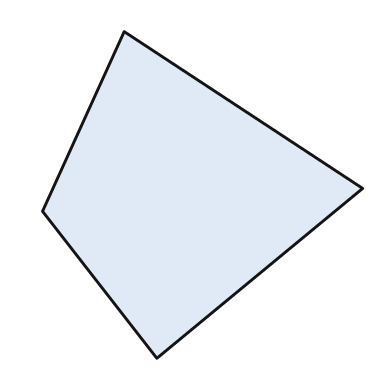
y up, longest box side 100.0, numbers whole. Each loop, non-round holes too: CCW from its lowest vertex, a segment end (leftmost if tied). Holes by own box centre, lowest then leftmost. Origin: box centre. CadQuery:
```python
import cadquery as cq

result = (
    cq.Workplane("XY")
    .moveTo(-14.0, -50.0)
    .lineTo(49.0, 2.0)
    .lineTo(-24.0, 50.0)
    .lineTo(-49.0, -5.0)
    .close()
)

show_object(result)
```